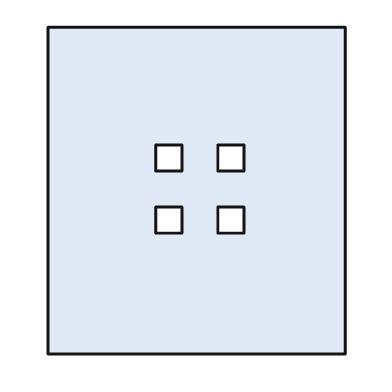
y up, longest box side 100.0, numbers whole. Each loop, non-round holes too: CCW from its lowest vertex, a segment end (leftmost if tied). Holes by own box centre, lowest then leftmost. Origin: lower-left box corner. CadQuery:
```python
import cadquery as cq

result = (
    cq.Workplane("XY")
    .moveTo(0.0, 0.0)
    .lineTo(91.0, 0.0)
    .lineTo(91.0, 100.0)
    .lineTo(0.0, 100.0)
    .close()
    .moveTo(33.0, 37.0)
    .lineTo(41.0, 37.0)
    .lineTo(41.0, 45.0)
    .lineTo(33.0, 45.0)
    .close()
    .moveTo(52.0, 37.0)
    .lineTo(60.0, 37.0)
    .lineTo(60.0, 45.0)
    .lineTo(52.0, 45.0)
    .close()
    .moveTo(33.0, 56.0)
    .lineTo(41.0, 56.0)
    .lineTo(41.0, 64.0)
    .lineTo(33.0, 64.0)
    .close()
    .moveTo(52.0, 56.0)
    .lineTo(60.0, 56.0)
    .lineTo(60.0, 64.0)
    .lineTo(52.0, 64.0)
    .close()
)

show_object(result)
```